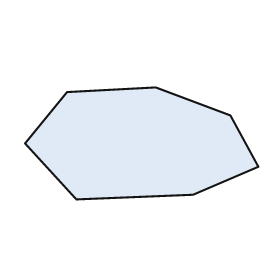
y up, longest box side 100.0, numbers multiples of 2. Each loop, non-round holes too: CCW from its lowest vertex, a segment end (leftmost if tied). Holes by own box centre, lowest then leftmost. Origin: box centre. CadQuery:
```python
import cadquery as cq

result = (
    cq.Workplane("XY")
    .moveTo(-28.0, -24.0)
    .lineTo(22.0, -22.0)
    .lineTo(50.0, -10.0)
    .lineTo(38.0, 12.0)
    .lineTo(6.0, 24.0)
    .lineTo(-32.0, 22.0)
    .lineTo(-50.0, 0.0)
    .close()
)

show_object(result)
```